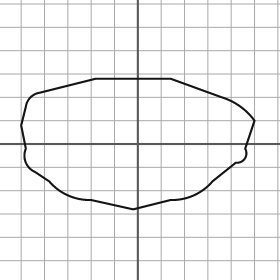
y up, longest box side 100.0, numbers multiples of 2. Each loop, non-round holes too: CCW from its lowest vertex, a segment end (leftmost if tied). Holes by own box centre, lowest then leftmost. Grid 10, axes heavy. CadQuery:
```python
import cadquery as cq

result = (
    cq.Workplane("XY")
    .moveTo(-2.0, -28.0)
    .lineTo(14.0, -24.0)
    .threePointArc((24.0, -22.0), (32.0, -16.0))
    .lineTo(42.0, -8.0)
    .threePointArc((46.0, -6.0), (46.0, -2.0))
    .lineTo(50.0, 10.0)
    .threePointArc((44.0, 16.0), (36.0, 20.0))
    .lineTo(14.0, 28.0)
    .lineTo(-18.0, 28.0)
    .lineTo(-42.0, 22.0)
    .threePointArc((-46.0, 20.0), (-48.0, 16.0))
    .lineTo(-50.0, 8.0)
    .lineTo(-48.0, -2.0)
    .threePointArc((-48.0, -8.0), (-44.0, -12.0))
    .lineTo(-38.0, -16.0)
    .threePointArc((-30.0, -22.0), (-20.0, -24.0))
    .close()
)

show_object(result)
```